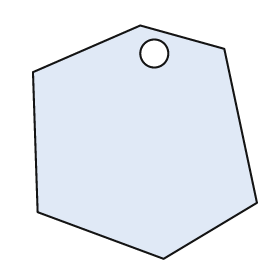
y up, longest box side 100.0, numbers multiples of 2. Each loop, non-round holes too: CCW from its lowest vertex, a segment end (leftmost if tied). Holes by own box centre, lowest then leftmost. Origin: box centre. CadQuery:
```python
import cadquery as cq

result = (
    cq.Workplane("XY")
    .moveTo(8.0, -50.0)
    .lineTo(48.0, -26.0)
    .lineTo(34.0, 40.0)
    .lineTo(-2.0, 50.0)
    .lineTo(-48.0, 30.0)
    .lineTo(-46.0, -30.0)
    .close()
    .moveTo(4.0, 38.0)
    .circle(6.0)
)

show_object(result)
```